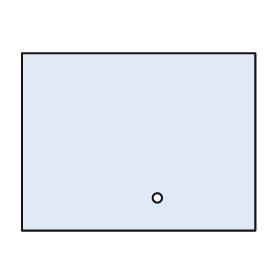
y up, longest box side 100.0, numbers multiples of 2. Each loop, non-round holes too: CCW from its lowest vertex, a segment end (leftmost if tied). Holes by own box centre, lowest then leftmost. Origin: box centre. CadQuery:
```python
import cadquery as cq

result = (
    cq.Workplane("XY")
    .moveTo(-50.0, -38.0)
    .lineTo(50.0, -38.0)
    .lineTo(50.0, 38.0)
    .lineTo(-50.0, 38.0)
    .close()
    .moveTo(8.0, -24.0)
    .circle(2.0)
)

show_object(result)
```